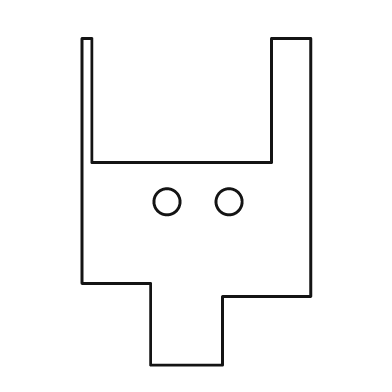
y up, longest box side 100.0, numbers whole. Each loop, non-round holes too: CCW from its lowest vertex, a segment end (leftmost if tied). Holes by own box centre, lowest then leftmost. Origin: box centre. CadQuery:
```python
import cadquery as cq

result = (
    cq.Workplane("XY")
    .moveTo(-14.0, -50.0)
    .lineTo(8.0, -50.0)
    .lineTo(8.0, -29.0)
    .lineTo(35.0, -29.0)
    .lineTo(35.0, 50.0)
    .lineTo(23.0, 50.0)
    .lineTo(23.0, 12.0)
    .lineTo(-32.0, 12.0)
    .lineTo(-32.0, 50.0)
    .lineTo(-35.0, 50.0)
    .lineTo(-35.0, -25.0)
    .lineTo(-14.0, -25.0)
    .close()
    .moveTo(-9.0, 0.0)
    .circle(4.0)
    .moveTo(10.0, 0.0)
    .circle(4.0)
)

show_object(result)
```